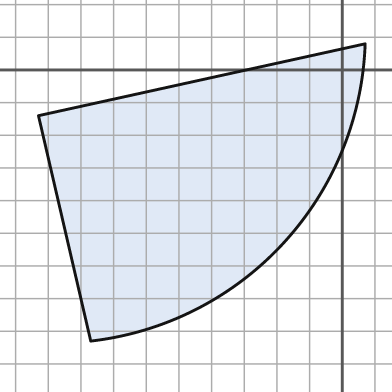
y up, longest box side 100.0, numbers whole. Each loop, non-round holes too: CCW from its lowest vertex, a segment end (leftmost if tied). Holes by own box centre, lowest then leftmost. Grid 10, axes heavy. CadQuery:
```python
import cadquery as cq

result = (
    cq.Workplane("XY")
    .moveTo(-77.0, -83.0)
    .threePointArc((-18.0, -53.0), (7.0, 8.0))
    .lineTo(-93.0, -14.0)
    .close()
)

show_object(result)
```